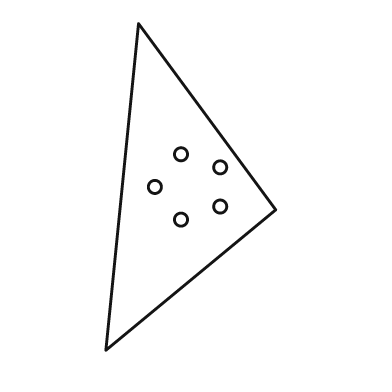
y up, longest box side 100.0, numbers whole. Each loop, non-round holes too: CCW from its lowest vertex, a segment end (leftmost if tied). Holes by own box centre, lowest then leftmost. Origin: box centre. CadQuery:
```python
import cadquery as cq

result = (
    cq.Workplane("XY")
    .moveTo(-26.0, -50.0)
    .lineTo(26.0, -7.0)
    .lineTo(-16.0, 50.0)
    .close()
    .moveTo(-3.0, -10.0)
    .circle(2.0)
    .moveTo(9.0, -6.0)
    .circle(2.0)
    .moveTo(-11.0, 0.0)
    .circle(2.0)
    .moveTo(9.0, 6.0)
    .circle(2.0)
    .moveTo(-3.0, 10.0)
    .circle(2.0)
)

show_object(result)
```